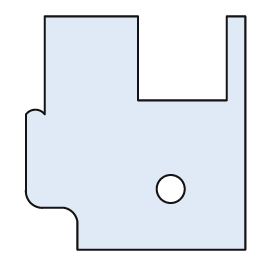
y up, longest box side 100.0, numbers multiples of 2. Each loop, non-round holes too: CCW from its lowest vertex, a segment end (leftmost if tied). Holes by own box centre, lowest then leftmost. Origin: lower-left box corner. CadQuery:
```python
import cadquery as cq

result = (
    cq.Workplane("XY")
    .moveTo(22.0, 0.0)
    .lineTo(94.0, 0.0)
    .lineTo(94.0, 100.0)
    .lineTo(86.0, 100.0)
    .lineTo(86.0, 64.0)
    .lineTo(48.0, 64.0)
    .lineTo(48.0, 100.0)
    .lineTo(8.0, 100.0)
    .lineTo(8.0, 58.0)
    .threePointArc((4.0, 60.0), (0.0, 58.0))
    .lineTo(0.0, 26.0)
    .threePointArc((2.0, 20.0), (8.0, 18.0))
    .lineTo(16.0, 18.0)
    .threePointArc((20.0, 16.0), (22.0, 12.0))
    .close()
    .moveTo(62.0, 26.0)
    .circle(6.0)
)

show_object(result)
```